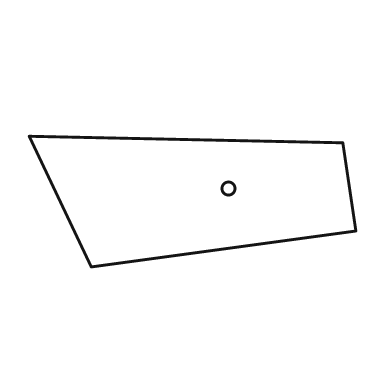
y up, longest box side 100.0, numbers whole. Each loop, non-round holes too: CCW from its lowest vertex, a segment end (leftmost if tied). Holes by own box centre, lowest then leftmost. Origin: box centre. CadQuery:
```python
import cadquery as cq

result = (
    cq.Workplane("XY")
    .moveTo(-31.0, -20.0)
    .lineTo(50.0, -9.0)
    .lineTo(46.0, 18.0)
    .lineTo(-50.0, 20.0)
    .close()
    .moveTo(11.0, 4.0)
    .circle(2.0)
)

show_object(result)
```